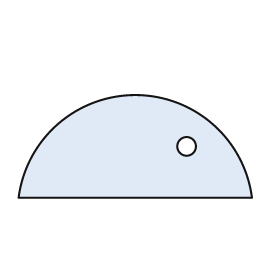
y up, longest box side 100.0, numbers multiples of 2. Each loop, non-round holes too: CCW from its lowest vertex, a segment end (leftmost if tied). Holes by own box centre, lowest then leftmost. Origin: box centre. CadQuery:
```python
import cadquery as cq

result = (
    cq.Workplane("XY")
    .moveTo(-50.0, -22.0)
    .lineTo(50.0, -22.0)
    .threePointArc((0.0, 22.0), (-50.0, -22.0))
    .close()
    .moveTo(22.0, 0.0)
    .circle(4.0)
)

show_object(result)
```